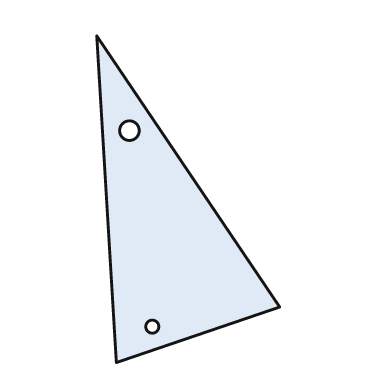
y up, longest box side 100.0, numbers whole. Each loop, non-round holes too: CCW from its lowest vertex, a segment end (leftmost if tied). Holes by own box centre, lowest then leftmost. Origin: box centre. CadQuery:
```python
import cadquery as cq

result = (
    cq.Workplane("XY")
    .moveTo(-22.0, -50.0)
    .lineTo(28.0, -33.0)
    .lineTo(-28.0, 50.0)
    .close()
    .moveTo(-11.0, -39.0)
    .circle(2.0)
    .moveTo(-18.0, 21.0)
    .circle(3.0)
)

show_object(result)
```